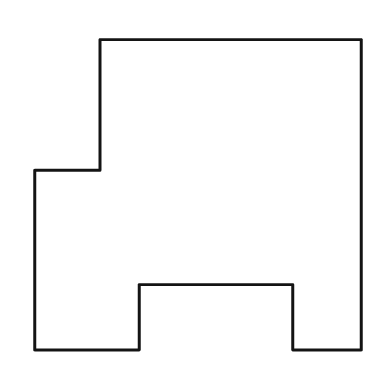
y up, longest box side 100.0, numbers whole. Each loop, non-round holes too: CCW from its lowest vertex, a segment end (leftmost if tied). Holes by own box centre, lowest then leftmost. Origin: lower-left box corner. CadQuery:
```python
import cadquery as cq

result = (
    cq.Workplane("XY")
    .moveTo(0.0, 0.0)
    .lineTo(32.0, 0.0)
    .lineTo(32.0, 20.0)
    .lineTo(79.0, 20.0)
    .lineTo(79.0, 0.0)
    .lineTo(100.0, 0.0)
    .lineTo(100.0, 95.0)
    .lineTo(20.0, 95.0)
    .lineTo(20.0, 55.0)
    .lineTo(0.0, 55.0)
    .close()
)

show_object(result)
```